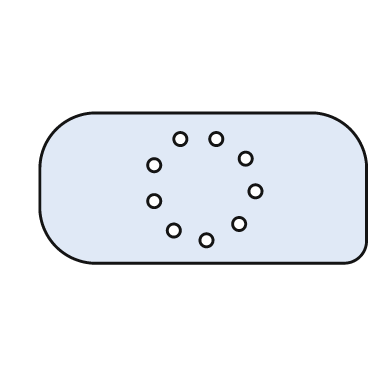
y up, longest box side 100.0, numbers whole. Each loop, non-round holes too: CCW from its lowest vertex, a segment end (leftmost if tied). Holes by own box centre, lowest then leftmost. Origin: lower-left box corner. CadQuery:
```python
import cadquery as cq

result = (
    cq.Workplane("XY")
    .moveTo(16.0, 0.0)
    .lineTo(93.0, 0.0)
    .threePointArc((98.0, 2.0), (100.0, 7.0))
    .lineTo(100.0, 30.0)
    .threePointArc((95.0, 41.0), (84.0, 46.0))
    .lineTo(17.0, 46.0)
    .threePointArc((5.0, 41.0), (0.0, 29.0))
    .lineTo(0.0, 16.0)
    .threePointArc((5.0, 5.0), (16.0, 0.0))
    .close()
    .moveTo(51.0, 7.0)
    .circle(2.0)
    .moveTo(41.0, 10.0)
    .circle(2.0)
    .moveTo(61.0, 12.0)
    .circle(2.0)
    .moveTo(35.0, 19.0)
    .circle(2.0)
    .moveTo(66.0, 22.0)
    .circle(2.0)
    .moveTo(35.0, 30.0)
    .circle(2.0)
    .moveTo(63.0, 32.0)
    .circle(2.0)
    .moveTo(43.0, 38.0)
    .circle(2.0)
    .moveTo(54.0, 38.0)
    .circle(2.0)
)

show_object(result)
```